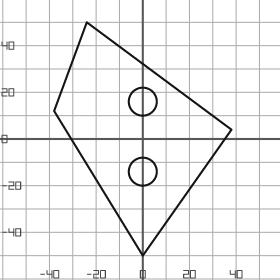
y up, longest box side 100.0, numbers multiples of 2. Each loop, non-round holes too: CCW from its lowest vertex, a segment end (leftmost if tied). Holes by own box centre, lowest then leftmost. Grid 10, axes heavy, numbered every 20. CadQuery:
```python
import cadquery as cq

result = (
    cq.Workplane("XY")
    .moveTo(0.0, -50.0)
    .lineTo(38.0, 4.0)
    .lineTo(-24.0, 50.0)
    .lineTo(-38.0, 12.0)
    .close()
    .moveTo(0.0, -14.0)
    .circle(6.0)
    .moveTo(0.0, 16.0)
    .circle(6.0)
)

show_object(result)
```